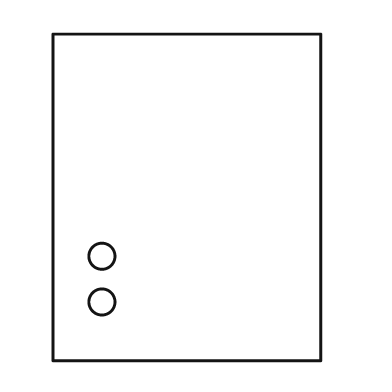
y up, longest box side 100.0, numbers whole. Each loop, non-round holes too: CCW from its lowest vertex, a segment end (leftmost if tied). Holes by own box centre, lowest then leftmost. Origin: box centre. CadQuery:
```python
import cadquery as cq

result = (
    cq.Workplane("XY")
    .moveTo(-41.0, -50.0)
    .lineTo(41.0, -50.0)
    .lineTo(41.0, 50.0)
    .lineTo(-41.0, 50.0)
    .close()
    .moveTo(-26.0, -32.0)
    .circle(4.0)
    .moveTo(-26.0, -18.0)
    .circle(4.0)
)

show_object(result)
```